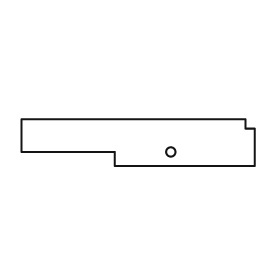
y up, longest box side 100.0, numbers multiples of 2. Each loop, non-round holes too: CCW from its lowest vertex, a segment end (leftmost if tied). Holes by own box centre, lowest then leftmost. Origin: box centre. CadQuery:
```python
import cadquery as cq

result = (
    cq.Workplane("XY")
    .moveTo(-10.0, -10.0)
    .lineTo(50.0, -10.0)
    .lineTo(50.0, 6.0)
    .lineTo(46.0, 6.0)
    .lineTo(46.0, 10.0)
    .lineTo(-50.0, 10.0)
    .lineTo(-50.0, -4.0)
    .lineTo(-10.0, -4.0)
    .close()
    .moveTo(14.0, -4.0)
    .circle(2.0)
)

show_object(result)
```